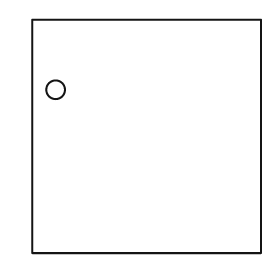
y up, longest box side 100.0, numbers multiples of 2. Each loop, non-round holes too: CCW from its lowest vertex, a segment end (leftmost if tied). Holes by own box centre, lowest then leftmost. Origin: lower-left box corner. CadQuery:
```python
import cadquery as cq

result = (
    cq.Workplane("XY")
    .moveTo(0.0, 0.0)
    .lineTo(98.0, 0.0)
    .lineTo(98.0, 100.0)
    .lineTo(0.0, 100.0)
    .close()
    .moveTo(10.0, 70.0)
    .circle(4.0)
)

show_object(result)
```